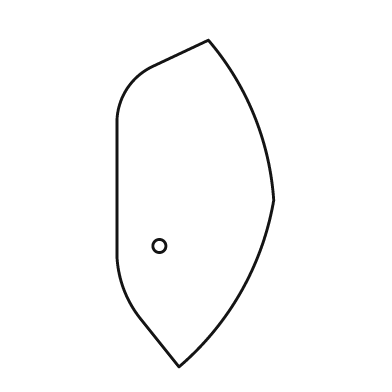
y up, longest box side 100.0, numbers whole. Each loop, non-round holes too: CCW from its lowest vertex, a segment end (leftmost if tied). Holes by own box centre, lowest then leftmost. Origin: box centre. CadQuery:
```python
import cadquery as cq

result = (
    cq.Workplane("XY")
    .moveTo(-5.0, -50.0)
    .threePointArc((14.0, -27.0), (24.0, 1.0))
    .threePointArc((18.0, 27.0), (4.0, 50.0))
    .lineTo(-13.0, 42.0)
    .threePointArc((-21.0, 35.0), (-24.0, 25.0))
    .lineTo(-24.0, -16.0)
    .threePointArc((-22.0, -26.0), (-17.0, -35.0))
    .close()
    .moveTo(-11.0, -13.0)
    .circle(2.0)
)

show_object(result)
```